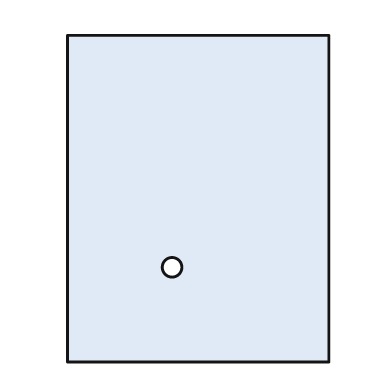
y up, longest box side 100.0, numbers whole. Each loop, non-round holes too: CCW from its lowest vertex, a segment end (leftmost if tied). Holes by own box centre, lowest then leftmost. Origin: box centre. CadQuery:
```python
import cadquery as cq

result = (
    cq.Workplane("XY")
    .moveTo(-40.0, -50.0)
    .lineTo(40.0, -50.0)
    .lineTo(40.0, 50.0)
    .lineTo(-40.0, 50.0)
    .close()
    .moveTo(-8.0, -21.0)
    .circle(3.0)
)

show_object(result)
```